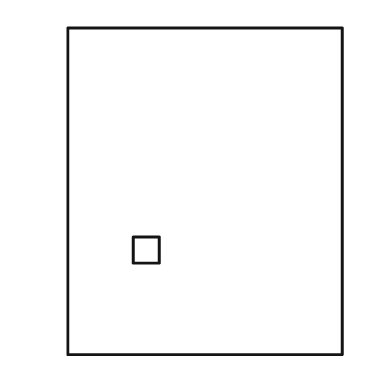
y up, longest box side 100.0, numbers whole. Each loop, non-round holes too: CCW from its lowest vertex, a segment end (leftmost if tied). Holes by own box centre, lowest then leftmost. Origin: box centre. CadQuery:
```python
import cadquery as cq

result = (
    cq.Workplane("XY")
    .moveTo(-42.0, -50.0)
    .lineTo(42.0, -50.0)
    .lineTo(42.0, 50.0)
    .lineTo(-42.0, 50.0)
    .close()
    .moveTo(-22.0, -22.0)
    .lineTo(-14.0, -22.0)
    .lineTo(-14.0, -14.0)
    .lineTo(-22.0, -14.0)
    .close()
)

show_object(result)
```